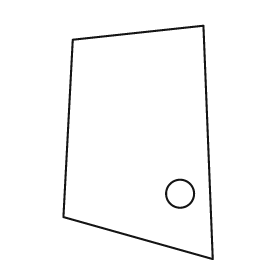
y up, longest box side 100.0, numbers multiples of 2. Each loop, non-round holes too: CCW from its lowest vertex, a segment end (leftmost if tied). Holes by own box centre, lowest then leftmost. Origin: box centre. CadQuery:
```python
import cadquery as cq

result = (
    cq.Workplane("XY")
    .moveTo(32.0, -50.0)
    .lineTo(28.0, 50.0)
    .lineTo(-28.0, 44.0)
    .lineTo(-32.0, -32.0)
    .close()
    .moveTo(18.0, -22.0)
    .circle(6.0)
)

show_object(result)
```